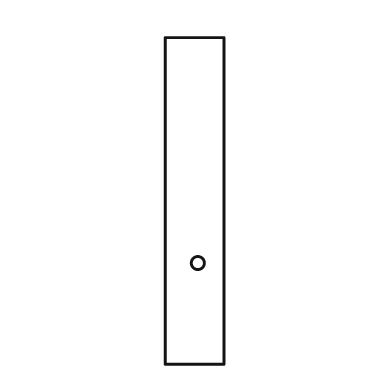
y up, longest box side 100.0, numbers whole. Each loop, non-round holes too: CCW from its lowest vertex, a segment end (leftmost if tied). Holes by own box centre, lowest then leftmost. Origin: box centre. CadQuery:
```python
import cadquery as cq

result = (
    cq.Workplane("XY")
    .moveTo(-9.0, -50.0)
    .lineTo(9.0, -50.0)
    .lineTo(9.0, 50.0)
    .lineTo(-9.0, 50.0)
    .close()
    .moveTo(1.0, -19.0)
    .circle(2.0)
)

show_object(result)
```